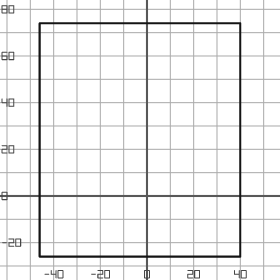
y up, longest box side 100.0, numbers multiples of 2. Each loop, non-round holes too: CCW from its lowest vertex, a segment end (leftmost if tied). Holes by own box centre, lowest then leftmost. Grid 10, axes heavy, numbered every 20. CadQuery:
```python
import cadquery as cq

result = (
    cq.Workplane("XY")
    .moveTo(-46.0, -26.0)
    .lineTo(40.0, -26.0)
    .lineTo(40.0, 74.0)
    .lineTo(-46.0, 74.0)
    .close()
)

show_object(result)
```